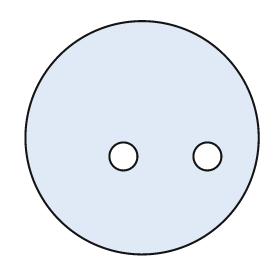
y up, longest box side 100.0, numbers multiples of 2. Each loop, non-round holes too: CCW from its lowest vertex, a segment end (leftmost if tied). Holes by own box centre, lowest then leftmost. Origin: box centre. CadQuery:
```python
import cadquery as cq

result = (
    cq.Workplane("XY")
    .moveTo(0.0, 0.0)
    .circle(50.0)
    .moveTo(-8.0, -8.0)
    .circle(6.0)
    .moveTo(28.0, -8.0)
    .circle(6.0)
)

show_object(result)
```